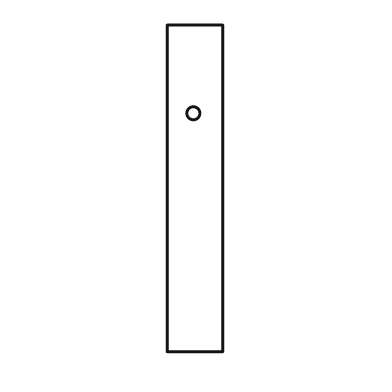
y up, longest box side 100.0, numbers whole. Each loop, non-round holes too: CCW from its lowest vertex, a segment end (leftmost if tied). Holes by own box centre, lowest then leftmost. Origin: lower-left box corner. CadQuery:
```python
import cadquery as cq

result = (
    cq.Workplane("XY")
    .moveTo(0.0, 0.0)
    .lineTo(17.0, 0.0)
    .lineTo(17.0, 100.0)
    .lineTo(0.0, 100.0)
    .close()
    .moveTo(8.0, 73.0)
    .circle(2.0)
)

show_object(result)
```